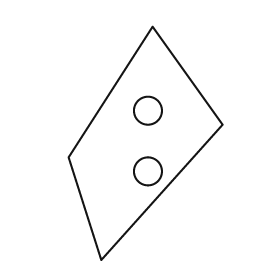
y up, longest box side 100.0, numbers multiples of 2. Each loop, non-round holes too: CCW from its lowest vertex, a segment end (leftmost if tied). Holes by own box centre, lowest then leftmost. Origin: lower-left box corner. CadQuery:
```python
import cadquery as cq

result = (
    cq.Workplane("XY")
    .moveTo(14.0, 0.0)
    .lineTo(66.0, 58.0)
    .lineTo(36.0, 100.0)
    .lineTo(0.0, 44.0)
    .close()
    .moveTo(34.0, 38.0)
    .circle(6.0)
    .moveTo(34.0, 64.0)
    .circle(6.0)
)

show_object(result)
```